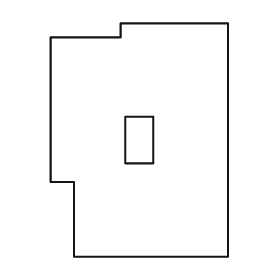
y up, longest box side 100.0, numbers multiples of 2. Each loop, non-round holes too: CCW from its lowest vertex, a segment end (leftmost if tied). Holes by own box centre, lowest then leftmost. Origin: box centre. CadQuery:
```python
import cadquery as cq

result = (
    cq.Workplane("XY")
    .moveTo(-28.0, -50.0)
    .lineTo(38.0, -50.0)
    .lineTo(38.0, 50.0)
    .lineTo(-8.0, 50.0)
    .lineTo(-8.0, 44.0)
    .lineTo(-38.0, 44.0)
    .lineTo(-38.0, -18.0)
    .lineTo(-28.0, -18.0)
    .close()
    .moveTo(-6.0, -10.0)
    .lineTo(6.0, -10.0)
    .lineTo(6.0, 10.0)
    .lineTo(-6.0, 10.0)
    .close()
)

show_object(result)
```